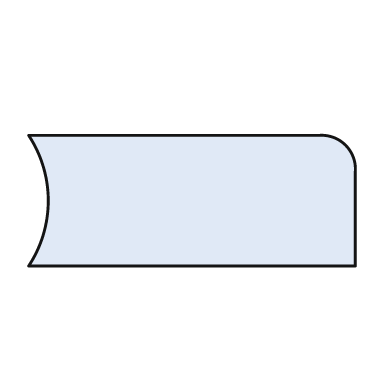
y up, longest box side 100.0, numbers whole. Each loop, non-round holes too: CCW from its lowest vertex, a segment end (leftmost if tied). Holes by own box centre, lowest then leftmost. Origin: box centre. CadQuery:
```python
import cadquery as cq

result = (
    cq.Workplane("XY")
    .moveTo(-50.0, -20.0)
    .lineTo(50.0, -20.0)
    .lineTo(50.0, 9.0)
    .threePointArc((47.0, 17.0), (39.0, 20.0))
    .lineTo(-50.0, 20.0)
    .threePointArc((-44.0, 0.0), (-50.0, -20.0))
    .close()
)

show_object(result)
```